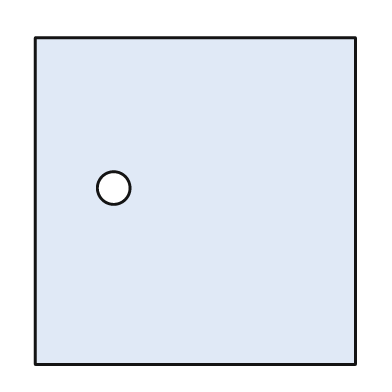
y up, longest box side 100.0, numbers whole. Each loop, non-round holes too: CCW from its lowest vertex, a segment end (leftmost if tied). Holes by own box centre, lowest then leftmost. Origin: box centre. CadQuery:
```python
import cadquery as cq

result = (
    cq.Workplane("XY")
    .moveTo(-49.0, -50.0)
    .lineTo(49.0, -50.0)
    .lineTo(49.0, 50.0)
    .lineTo(-49.0, 50.0)
    .close()
    .moveTo(-25.0, 4.0)
    .circle(5.0)
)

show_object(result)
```